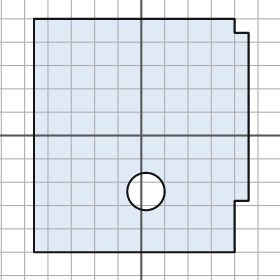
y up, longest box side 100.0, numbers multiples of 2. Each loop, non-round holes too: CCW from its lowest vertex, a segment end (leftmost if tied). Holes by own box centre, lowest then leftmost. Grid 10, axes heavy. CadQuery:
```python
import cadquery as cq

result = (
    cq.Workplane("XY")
    .moveTo(-46.0, -50.0)
    .lineTo(40.0, -50.0)
    .lineTo(40.0, -28.0)
    .lineTo(46.0, -28.0)
    .lineTo(46.0, 44.0)
    .lineTo(40.0, 44.0)
    .lineTo(40.0, 50.0)
    .lineTo(-46.0, 50.0)
    .close()
    .moveTo(2.0, -24.0)
    .circle(8.0)
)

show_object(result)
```